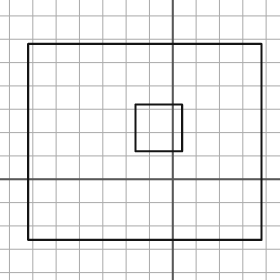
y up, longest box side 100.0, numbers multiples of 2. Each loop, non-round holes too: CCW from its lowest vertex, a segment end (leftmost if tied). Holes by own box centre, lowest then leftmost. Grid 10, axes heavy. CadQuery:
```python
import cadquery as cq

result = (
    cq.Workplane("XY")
    .moveTo(-62.0, -26.0)
    .lineTo(38.0, -26.0)
    .lineTo(38.0, 58.0)
    .lineTo(-62.0, 58.0)
    .close()
    .moveTo(-16.0, 12.0)
    .lineTo(4.0, 12.0)
    .lineTo(4.0, 32.0)
    .lineTo(-16.0, 32.0)
    .close()
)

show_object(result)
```